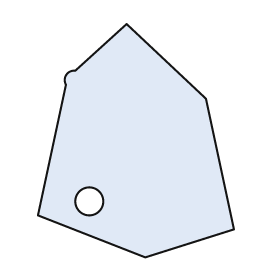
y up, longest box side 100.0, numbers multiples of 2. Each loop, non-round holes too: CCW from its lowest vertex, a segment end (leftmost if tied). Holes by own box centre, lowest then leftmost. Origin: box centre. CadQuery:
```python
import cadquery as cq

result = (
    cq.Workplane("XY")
    .moveTo(4.0, -50.0)
    .lineTo(42.0, -38.0)
    .lineTo(30.0, 18.0)
    .lineTo(-4.0, 50.0)
    .lineTo(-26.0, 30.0)
    .threePointArc((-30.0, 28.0), (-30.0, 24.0))
    .lineTo(-42.0, -32.0)
    .close()
    .moveTo(-20.0, -26.0)
    .circle(6.0)
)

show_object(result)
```